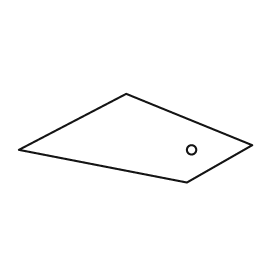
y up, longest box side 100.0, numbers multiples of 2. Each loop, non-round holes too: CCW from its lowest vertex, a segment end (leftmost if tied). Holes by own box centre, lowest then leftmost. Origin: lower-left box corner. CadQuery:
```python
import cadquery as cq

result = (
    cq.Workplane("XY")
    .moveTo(72.0, 0.0)
    .lineTo(100.0, 16.0)
    .lineTo(46.0, 38.0)
    .lineTo(0.0, 14.0)
    .close()
    .moveTo(74.0, 14.0)
    .circle(2.0)
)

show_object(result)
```